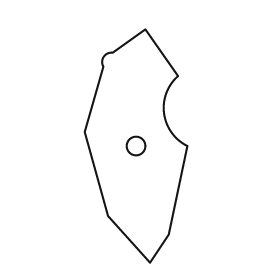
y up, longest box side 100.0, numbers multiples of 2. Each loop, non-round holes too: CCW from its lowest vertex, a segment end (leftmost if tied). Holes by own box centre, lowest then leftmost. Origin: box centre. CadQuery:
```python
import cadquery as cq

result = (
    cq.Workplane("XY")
    .moveTo(6.0, -50.0)
    .lineTo(14.0, -38.0)
    .lineTo(22.0, 0.0)
    .threePointArc((12.0, 14.0), (18.0, 30.0))
    .lineTo(4.0, 50.0)
    .lineTo(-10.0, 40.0)
    .threePointArc((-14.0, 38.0), (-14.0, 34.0))
    .lineTo(-22.0, 6.0)
    .lineTo(-12.0, -30.0)
    .close()
    .moveTo(0.0, 0.0)
    .circle(4.0)
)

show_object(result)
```